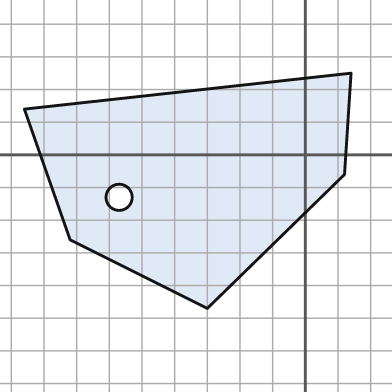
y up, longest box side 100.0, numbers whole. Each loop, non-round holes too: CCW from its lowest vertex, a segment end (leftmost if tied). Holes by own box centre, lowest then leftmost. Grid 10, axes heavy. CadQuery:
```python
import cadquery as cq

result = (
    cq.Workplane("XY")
    .moveTo(-30.0, -47.0)
    .lineTo(12.0, -6.0)
    .lineTo(14.0, 25.0)
    .lineTo(-86.0, 14.0)
    .lineTo(-72.0, -26.0)
    .close()
    .moveTo(-57.0, -13.0)
    .circle(4.0)
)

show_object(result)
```